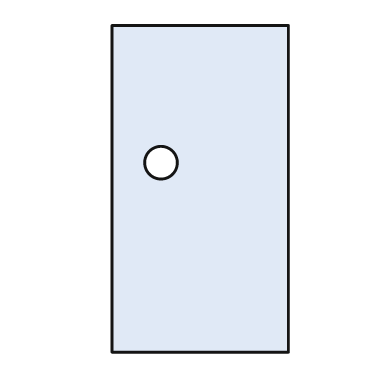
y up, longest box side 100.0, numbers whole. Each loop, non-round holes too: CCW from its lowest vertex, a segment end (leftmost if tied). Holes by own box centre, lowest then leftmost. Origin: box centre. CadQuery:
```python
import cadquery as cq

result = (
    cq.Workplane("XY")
    .moveTo(-27.0, -50.0)
    .lineTo(27.0, -50.0)
    .lineTo(27.0, 50.0)
    .lineTo(-27.0, 50.0)
    .close()
    .moveTo(-12.0, 8.0)
    .circle(5.0)
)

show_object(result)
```